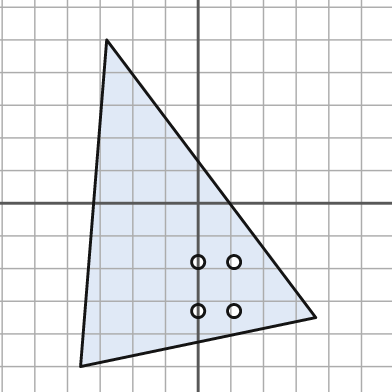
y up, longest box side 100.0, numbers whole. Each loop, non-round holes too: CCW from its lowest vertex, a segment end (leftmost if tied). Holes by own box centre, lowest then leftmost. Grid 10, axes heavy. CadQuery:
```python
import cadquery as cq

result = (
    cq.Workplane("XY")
    .moveTo(-36.0, -50.0)
    .lineTo(36.0, -35.0)
    .lineTo(-28.0, 50.0)
    .close()
    .moveTo(0.0, -33.0)
    .circle(2.0)
    .moveTo(11.0, -33.0)
    .circle(2.0)
    .moveTo(0.0, -18.0)
    .circle(2.0)
    .moveTo(11.0, -18.0)
    .circle(2.0)
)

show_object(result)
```